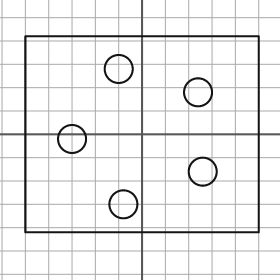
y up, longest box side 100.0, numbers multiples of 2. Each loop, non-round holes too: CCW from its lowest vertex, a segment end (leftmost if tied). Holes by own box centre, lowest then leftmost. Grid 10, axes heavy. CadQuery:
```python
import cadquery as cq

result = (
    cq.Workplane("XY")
    .moveTo(-50.0, -42.0)
    .lineTo(50.0, -42.0)
    .lineTo(50.0, 42.0)
    .lineTo(-50.0, 42.0)
    .close()
    .moveTo(-8.0, -30.0)
    .circle(6.0)
    .moveTo(26.0, -16.0)
    .circle(6.0)
    .moveTo(-30.0, -2.0)
    .circle(6.0)
    .moveTo(24.0, 18.0)
    .circle(6.0)
    .moveTo(-10.0, 28.0)
    .circle(6.0)
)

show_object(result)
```